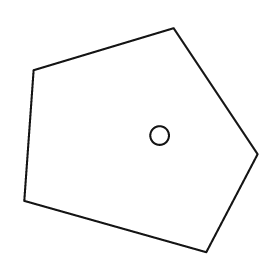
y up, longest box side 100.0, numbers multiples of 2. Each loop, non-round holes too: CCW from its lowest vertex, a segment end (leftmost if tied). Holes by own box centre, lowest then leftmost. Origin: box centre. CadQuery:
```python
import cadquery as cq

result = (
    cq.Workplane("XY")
    .moveTo(28.0, -48.0)
    .lineTo(50.0, -6.0)
    .lineTo(14.0, 48.0)
    .lineTo(-46.0, 30.0)
    .lineTo(-50.0, -26.0)
    .close()
    .moveTo(8.0, 2.0)
    .circle(4.0)
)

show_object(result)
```